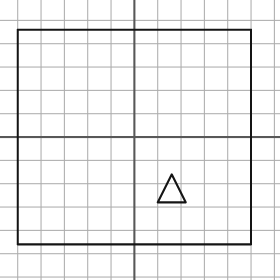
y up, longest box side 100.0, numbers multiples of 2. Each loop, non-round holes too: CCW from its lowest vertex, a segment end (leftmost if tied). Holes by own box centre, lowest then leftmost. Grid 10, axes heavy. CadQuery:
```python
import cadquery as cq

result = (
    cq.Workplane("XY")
    .moveTo(-50.0, -46.0)
    .lineTo(50.0, -46.0)
    .lineTo(50.0, 46.0)
    .lineTo(-50.0, 46.0)
    .close()
    .moveTo(10.0, -28.0)
    .lineTo(22.0, -28.0)
    .lineTo(16.0, -16.0)
    .close()
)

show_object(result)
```